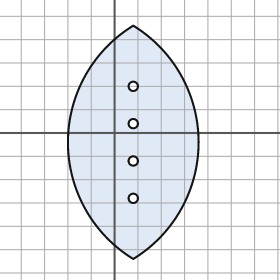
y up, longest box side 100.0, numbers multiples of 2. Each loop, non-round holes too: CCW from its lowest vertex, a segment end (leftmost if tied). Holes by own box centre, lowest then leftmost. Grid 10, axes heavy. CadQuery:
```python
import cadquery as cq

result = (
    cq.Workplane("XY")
    .moveTo(8.0, -54.0)
    .threePointArc((36.0, -4.0), (8.0, 46.0))
    .threePointArc((-20.0, -4.0), (8.0, -54.0))
    .close()
    .moveTo(8.0, -28.0)
    .circle(2.0)
    .moveTo(8.0, -12.0)
    .circle(2.0)
    .moveTo(8.0, 4.0)
    .circle(2.0)
    .moveTo(8.0, 20.0)
    .circle(2.0)
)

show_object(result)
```